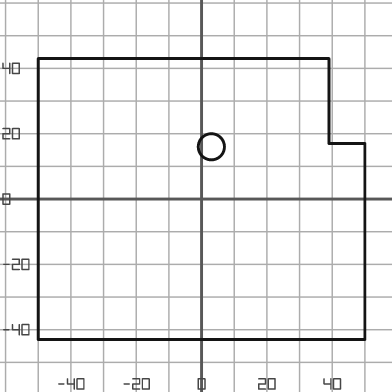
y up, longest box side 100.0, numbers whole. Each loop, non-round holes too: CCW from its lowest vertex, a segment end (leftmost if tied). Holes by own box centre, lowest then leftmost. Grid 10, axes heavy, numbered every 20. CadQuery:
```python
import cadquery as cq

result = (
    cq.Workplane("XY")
    .moveTo(-50.0, -43.0)
    .lineTo(50.0, -43.0)
    .lineTo(50.0, 17.0)
    .lineTo(39.0, 17.0)
    .lineTo(39.0, 43.0)
    .lineTo(-50.0, 43.0)
    .close()
    .moveTo(3.0, 16.0)
    .circle(4.0)
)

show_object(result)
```